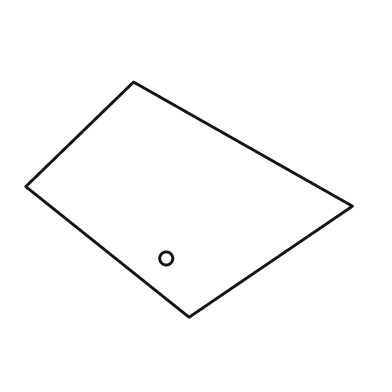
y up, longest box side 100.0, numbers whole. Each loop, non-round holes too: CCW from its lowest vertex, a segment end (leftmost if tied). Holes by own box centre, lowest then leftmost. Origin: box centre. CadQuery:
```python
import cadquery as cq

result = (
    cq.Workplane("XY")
    .moveTo(0.0, -36.0)
    .lineTo(50.0, -2.0)
    .lineTo(-17.0, 36.0)
    .lineTo(-50.0, 4.0)
    .close()
    .moveTo(-7.0, -18.0)
    .circle(2.0)
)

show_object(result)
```